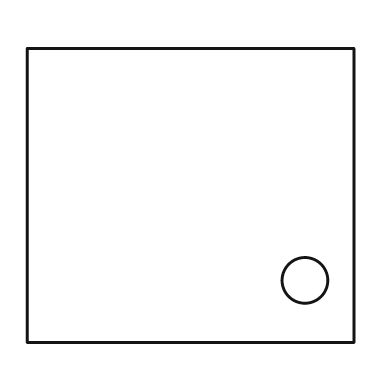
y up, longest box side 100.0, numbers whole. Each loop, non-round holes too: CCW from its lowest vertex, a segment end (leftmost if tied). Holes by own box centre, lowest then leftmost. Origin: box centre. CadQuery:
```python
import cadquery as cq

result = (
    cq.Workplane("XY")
    .moveTo(-50.0, -45.0)
    .lineTo(50.0, -45.0)
    .lineTo(50.0, 45.0)
    .lineTo(-50.0, 45.0)
    .close()
    .moveTo(35.0, -26.0)
    .circle(7.0)
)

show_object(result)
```